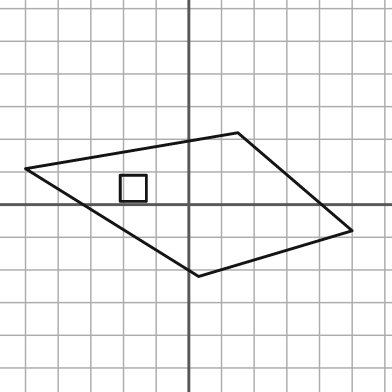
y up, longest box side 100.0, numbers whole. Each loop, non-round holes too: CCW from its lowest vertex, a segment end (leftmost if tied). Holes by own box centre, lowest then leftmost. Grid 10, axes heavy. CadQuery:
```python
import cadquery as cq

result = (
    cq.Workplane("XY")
    .moveTo(3.0, -22.0)
    .lineTo(50.0, -8.0)
    .lineTo(15.0, 22.0)
    .lineTo(-50.0, 11.0)
    .close()
    .moveTo(-21.0, 1.0)
    .lineTo(-13.0, 1.0)
    .lineTo(-13.0, 9.0)
    .lineTo(-21.0, 9.0)
    .close()
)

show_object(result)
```